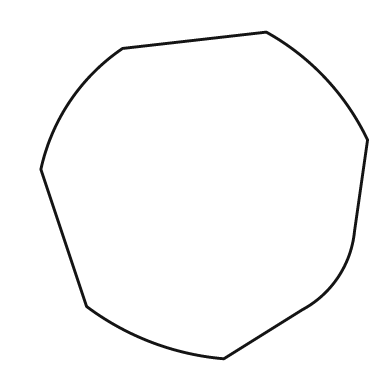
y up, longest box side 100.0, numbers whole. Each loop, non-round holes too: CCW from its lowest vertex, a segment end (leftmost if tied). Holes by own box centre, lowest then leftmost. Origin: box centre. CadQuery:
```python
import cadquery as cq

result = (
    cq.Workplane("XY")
    .moveTo(6.0, -50.0)
    .lineTo(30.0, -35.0)
    .threePointArc((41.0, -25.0), (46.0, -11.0))
    .lineTo(50.0, 17.0)
    .threePointArc((37.0, 36.0), (19.0, 50.0))
    .lineTo(-25.0, 45.0)
    .threePointArc((-41.0, 29.0), (-50.0, 8.0))
    .lineTo(-36.0, -34.0)
    .threePointArc((-16.0, -45.0), (6.0, -50.0))
    .close()
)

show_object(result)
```